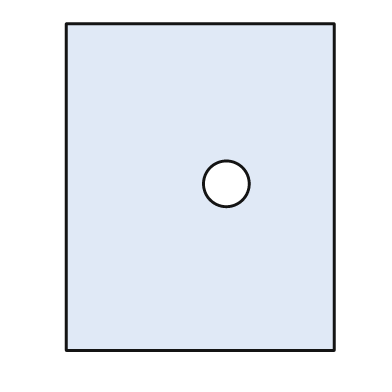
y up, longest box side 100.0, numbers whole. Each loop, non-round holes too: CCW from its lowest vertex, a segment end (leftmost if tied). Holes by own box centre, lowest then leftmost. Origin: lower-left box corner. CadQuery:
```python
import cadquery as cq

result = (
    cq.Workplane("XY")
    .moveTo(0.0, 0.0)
    .lineTo(82.0, 0.0)
    .lineTo(82.0, 100.0)
    .lineTo(0.0, 100.0)
    .close()
    .moveTo(49.0, 51.0)
    .circle(7.0)
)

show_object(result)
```